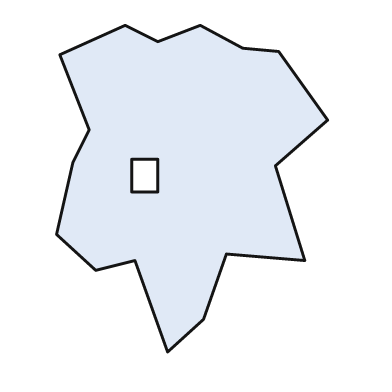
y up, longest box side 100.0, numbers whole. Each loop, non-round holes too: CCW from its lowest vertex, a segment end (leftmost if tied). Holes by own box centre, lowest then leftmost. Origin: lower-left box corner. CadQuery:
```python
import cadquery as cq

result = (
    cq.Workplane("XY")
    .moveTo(34.0, 0.0)
    .lineTo(45.0, 10.0)
    .lineTo(52.0, 30.0)
    .lineTo(76.0, 28.0)
    .lineTo(67.0, 57.0)
    .lineTo(83.0, 71.0)
    .lineTo(68.0, 92.0)
    .lineTo(57.0, 93.0)
    .lineTo(44.0, 100.0)
    .lineTo(31.0, 95.0)
    .lineTo(21.0, 100.0)
    .lineTo(1.0, 91.0)
    .lineTo(10.0, 68.0)
    .lineTo(5.0, 58.0)
    .lineTo(0.0, 36.0)
    .lineTo(12.0, 25.0)
    .lineTo(24.0, 28.0)
    .close()
    .moveTo(23.0, 49.0)
    .lineTo(31.0, 49.0)
    .lineTo(31.0, 59.0)
    .lineTo(23.0, 59.0)
    .close()
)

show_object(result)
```